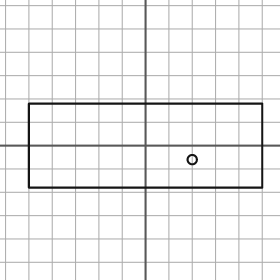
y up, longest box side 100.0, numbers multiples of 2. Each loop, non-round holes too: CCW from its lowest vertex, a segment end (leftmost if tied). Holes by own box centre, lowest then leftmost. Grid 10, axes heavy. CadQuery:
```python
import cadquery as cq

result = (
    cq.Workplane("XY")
    .moveTo(-50.0, -18.0)
    .lineTo(50.0, -18.0)
    .lineTo(50.0, 18.0)
    .lineTo(-50.0, 18.0)
    .close()
    .moveTo(20.0, -6.0)
    .circle(2.0)
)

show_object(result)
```